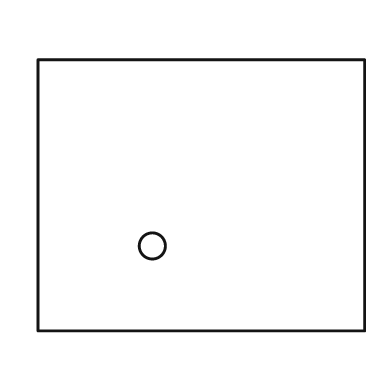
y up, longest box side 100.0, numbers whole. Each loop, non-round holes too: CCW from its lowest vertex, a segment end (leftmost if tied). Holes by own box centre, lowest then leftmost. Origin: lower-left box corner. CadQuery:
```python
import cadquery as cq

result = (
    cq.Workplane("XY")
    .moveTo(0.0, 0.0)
    .lineTo(100.0, 0.0)
    .lineTo(100.0, 83.0)
    .lineTo(0.0, 83.0)
    .close()
    .moveTo(35.0, 26.0)
    .circle(4.0)
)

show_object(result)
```